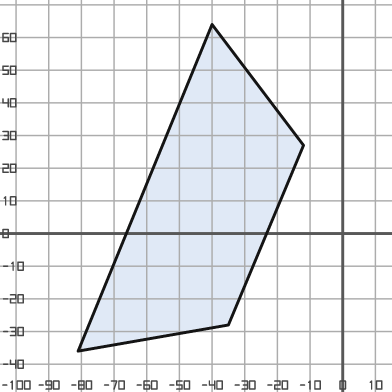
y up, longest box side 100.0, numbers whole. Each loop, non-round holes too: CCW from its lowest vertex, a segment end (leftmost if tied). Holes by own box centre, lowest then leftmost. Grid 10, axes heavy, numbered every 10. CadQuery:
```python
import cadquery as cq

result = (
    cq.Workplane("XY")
    .moveTo(-81.0, -36.0)
    .lineTo(-35.0, -28.0)
    .lineTo(-12.0, 27.0)
    .lineTo(-40.0, 64.0)
    .close()
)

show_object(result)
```